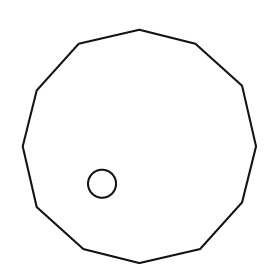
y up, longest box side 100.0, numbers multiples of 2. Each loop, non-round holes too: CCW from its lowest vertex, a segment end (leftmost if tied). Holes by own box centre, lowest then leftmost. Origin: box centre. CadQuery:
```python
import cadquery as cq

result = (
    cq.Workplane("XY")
    .moveTo(0.0, -50.0)
    .lineTo(26.0, -44.0)
    .lineTo(44.0, -24.0)
    .lineTo(50.0, 0.0)
    .lineTo(44.0, 26.0)
    .lineTo(24.0, 44.0)
    .lineTo(0.0, 50.0)
    .lineTo(-26.0, 44.0)
    .lineTo(-44.0, 24.0)
    .lineTo(-50.0, 0.0)
    .lineTo(-44.0, -26.0)
    .lineTo(-24.0, -44.0)
    .close()
    .moveTo(-16.0, -16.0)
    .circle(6.0)
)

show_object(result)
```